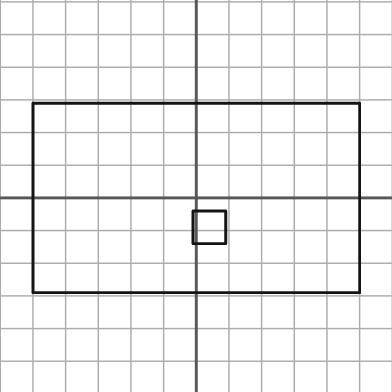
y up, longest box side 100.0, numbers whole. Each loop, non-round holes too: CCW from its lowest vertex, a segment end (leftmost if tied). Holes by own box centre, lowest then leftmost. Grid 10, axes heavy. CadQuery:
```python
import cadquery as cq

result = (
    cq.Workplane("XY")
    .moveTo(-50.0, -29.0)
    .lineTo(50.0, -29.0)
    .lineTo(50.0, 29.0)
    .lineTo(-50.0, 29.0)
    .close()
    .moveTo(-1.0, -14.0)
    .lineTo(9.0, -14.0)
    .lineTo(9.0, -4.0)
    .lineTo(-1.0, -4.0)
    .close()
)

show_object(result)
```